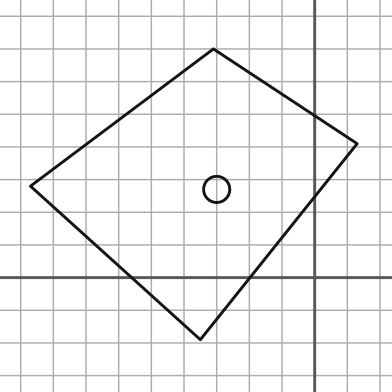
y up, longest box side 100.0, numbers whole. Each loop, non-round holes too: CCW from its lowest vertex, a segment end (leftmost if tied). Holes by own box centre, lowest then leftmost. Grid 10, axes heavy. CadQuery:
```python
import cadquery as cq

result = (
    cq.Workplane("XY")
    .moveTo(-35.0, -19.0)
    .lineTo(13.0, 41.0)
    .lineTo(-31.0, 70.0)
    .lineTo(-87.0, 28.0)
    .close()
    .moveTo(-30.0, 27.0)
    .circle(4.0)
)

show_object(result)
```